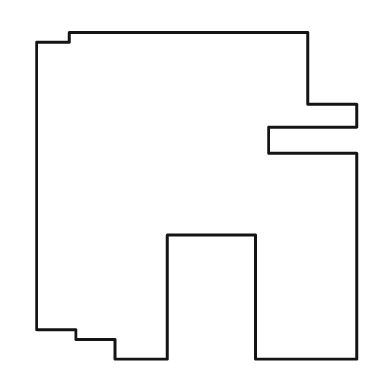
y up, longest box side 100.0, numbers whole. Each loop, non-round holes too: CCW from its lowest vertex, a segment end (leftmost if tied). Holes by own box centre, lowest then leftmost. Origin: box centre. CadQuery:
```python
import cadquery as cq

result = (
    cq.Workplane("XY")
    .moveTo(-25.0, -50.0)
    .lineTo(-9.0, -50.0)
    .lineTo(-9.0, -12.0)
    .lineTo(18.0, -12.0)
    .lineTo(18.0, -50.0)
    .lineTo(49.0, -50.0)
    .lineTo(49.0, 13.0)
    .lineTo(22.0, 13.0)
    .lineTo(22.0, 21.0)
    .lineTo(49.0, 21.0)
    .lineTo(49.0, 28.0)
    .lineTo(34.0, 28.0)
    .lineTo(34.0, 50.0)
    .lineTo(-39.0, 50.0)
    .lineTo(-39.0, 47.0)
    .lineTo(-49.0, 47.0)
    .lineTo(-49.0, -41.0)
    .lineTo(-37.0, -41.0)
    .lineTo(-37.0, -44.0)
    .lineTo(-25.0, -44.0)
    .close()
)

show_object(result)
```